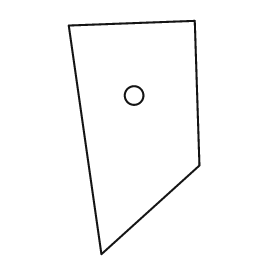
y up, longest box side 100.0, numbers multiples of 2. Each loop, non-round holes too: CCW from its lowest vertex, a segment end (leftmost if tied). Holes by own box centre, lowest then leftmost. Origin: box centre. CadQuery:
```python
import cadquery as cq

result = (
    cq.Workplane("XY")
    .moveTo(-14.0, -50.0)
    .lineTo(28.0, -12.0)
    .lineTo(26.0, 50.0)
    .lineTo(-28.0, 48.0)
    .close()
    .moveTo(0.0, 18.0)
    .circle(4.0)
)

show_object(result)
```